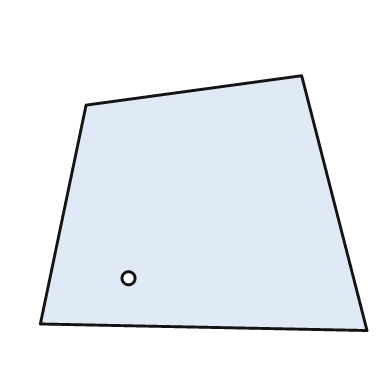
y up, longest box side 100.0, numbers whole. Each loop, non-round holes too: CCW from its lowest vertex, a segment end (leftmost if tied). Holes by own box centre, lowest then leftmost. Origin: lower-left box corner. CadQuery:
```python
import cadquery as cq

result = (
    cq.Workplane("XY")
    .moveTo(100.0, 0.0)
    .lineTo(80.0, 78.0)
    .lineTo(14.0, 69.0)
    .lineTo(0.0, 2.0)
    .close()
    .moveTo(27.0, 16.0)
    .circle(2.0)
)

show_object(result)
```